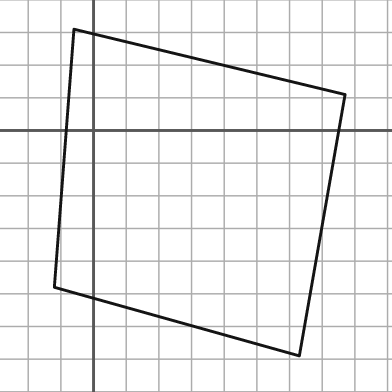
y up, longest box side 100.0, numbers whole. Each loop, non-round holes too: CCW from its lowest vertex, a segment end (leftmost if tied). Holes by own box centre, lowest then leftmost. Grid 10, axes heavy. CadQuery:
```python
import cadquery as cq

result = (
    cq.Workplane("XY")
    .moveTo(63.0, -69.0)
    .lineTo(77.0, 11.0)
    .lineTo(-6.0, 31.0)
    .lineTo(-12.0, -48.0)
    .close()
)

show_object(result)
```